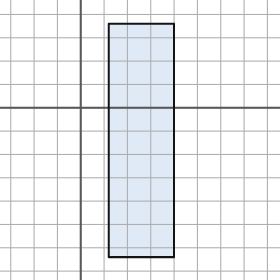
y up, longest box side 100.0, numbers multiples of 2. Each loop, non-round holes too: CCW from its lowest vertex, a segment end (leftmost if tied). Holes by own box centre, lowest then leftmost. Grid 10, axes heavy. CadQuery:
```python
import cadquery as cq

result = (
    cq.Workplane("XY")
    .moveTo(12.0, -64.0)
    .lineTo(40.0, -64.0)
    .lineTo(40.0, 36.0)
    .lineTo(12.0, 36.0)
    .close()
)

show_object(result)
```